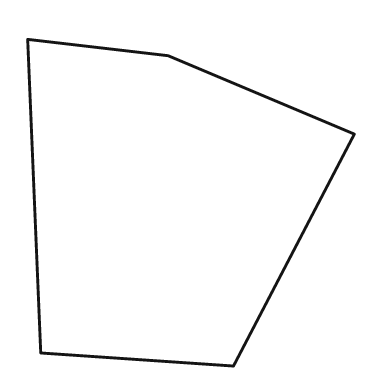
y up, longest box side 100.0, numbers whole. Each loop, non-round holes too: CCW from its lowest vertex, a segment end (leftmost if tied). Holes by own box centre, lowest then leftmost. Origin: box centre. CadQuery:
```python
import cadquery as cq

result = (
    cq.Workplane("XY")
    .moveTo(13.0, -50.0)
    .lineTo(50.0, 21.0)
    .lineTo(-7.0, 45.0)
    .lineTo(-50.0, 50.0)
    .lineTo(-46.0, -46.0)
    .close()
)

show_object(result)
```